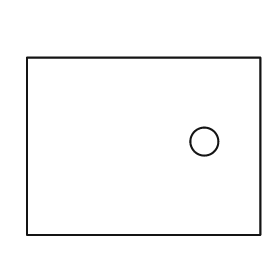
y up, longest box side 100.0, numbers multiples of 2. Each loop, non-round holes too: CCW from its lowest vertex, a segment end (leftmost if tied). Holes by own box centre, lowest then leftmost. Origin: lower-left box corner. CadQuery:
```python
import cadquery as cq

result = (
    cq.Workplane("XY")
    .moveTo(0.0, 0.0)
    .lineTo(100.0, 0.0)
    .lineTo(100.0, 76.0)
    .lineTo(0.0, 76.0)
    .close()
    .moveTo(76.0, 40.0)
    .circle(6.0)
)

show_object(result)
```